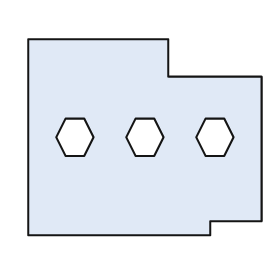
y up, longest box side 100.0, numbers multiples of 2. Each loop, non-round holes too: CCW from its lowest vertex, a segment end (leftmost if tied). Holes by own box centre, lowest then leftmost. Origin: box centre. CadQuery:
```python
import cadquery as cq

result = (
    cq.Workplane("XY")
    .moveTo(-50.0, -42.0)
    .lineTo(28.0, -42.0)
    .lineTo(28.0, -36.0)
    .lineTo(50.0, -36.0)
    .lineTo(50.0, 26.0)
    .lineTo(10.0, 26.0)
    .lineTo(10.0, 42.0)
    .lineTo(-50.0, 42.0)
    .close()
    .moveTo(-34.0, -8.0)
    .lineTo(-26.0, -8.0)
    .lineTo(-22.0, 0.0)
    .lineTo(-26.0, 8.0)
    .lineTo(-34.0, 8.0)
    .lineTo(-38.0, 0.0)
    .close()
    .moveTo(-4.0, -8.0)
    .lineTo(4.0, -8.0)
    .lineTo(8.0, 0.0)
    .lineTo(4.0, 8.0)
    .lineTo(-4.0, 8.0)
    .lineTo(-8.0, 0.0)
    .close()
    .moveTo(26.0, -8.0)
    .lineTo(34.0, -8.0)
    .lineTo(38.0, 0.0)
    .lineTo(34.0, 8.0)
    .lineTo(26.0, 8.0)
    .lineTo(22.0, 0.0)
    .close()
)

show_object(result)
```